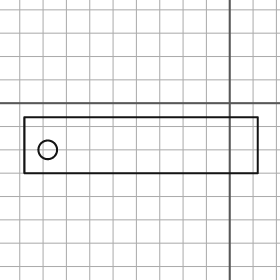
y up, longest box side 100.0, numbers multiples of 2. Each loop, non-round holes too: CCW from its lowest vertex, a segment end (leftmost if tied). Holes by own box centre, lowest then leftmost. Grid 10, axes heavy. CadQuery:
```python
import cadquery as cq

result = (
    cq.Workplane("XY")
    .moveTo(-88.0, -30.0)
    .lineTo(12.0, -30.0)
    .lineTo(12.0, -6.0)
    .lineTo(-88.0, -6.0)
    .close()
    .moveTo(-78.0, -20.0)
    .circle(4.0)
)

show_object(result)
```